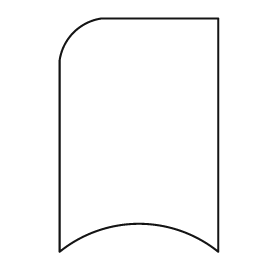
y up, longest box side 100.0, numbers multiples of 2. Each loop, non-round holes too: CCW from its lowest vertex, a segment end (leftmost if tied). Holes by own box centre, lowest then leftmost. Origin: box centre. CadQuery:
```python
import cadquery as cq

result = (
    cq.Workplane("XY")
    .moveTo(-34.0, -50.0)
    .threePointArc((0.0, -38.0), (34.0, -50.0))
    .lineTo(34.0, 50.0)
    .lineTo(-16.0, 50.0)
    .threePointArc((-28.0, 44.0), (-34.0, 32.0))
    .close()
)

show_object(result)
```